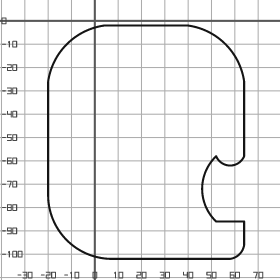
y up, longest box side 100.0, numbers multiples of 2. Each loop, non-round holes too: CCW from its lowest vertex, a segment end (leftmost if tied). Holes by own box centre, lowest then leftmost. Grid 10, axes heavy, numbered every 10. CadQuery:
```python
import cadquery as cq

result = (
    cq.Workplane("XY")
    .moveTo(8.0, -102.0)
    .lineTo(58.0, -102.0)
    .threePointArc((62.0, -100.0), (64.0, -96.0))
    .lineTo(64.0, -86.0)
    .lineTo(52.0, -86.0)
    .threePointArc((46.0, -72.0), (52.0, -58.0))
    .threePointArc((58.0, -62.0), (64.0, -58.0))
    .lineTo(64.0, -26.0)
    .threePointArc((56.0, -10.0), (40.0, -2.0))
    .lineTo(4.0, -2.0)
    .threePointArc((-12.0, -10.0), (-20.0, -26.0))
    .lineTo(-20.0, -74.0)
    .threePointArc((-12.0, -94.0), (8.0, -102.0))
    .close()
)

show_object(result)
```